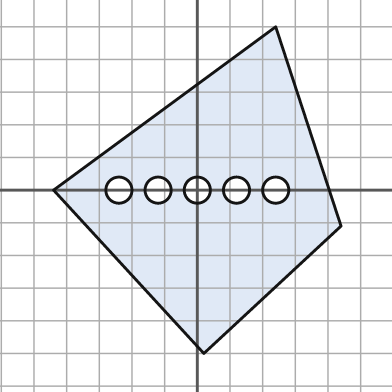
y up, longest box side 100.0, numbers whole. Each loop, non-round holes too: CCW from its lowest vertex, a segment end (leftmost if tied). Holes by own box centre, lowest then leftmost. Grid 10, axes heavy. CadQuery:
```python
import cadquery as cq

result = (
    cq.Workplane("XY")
    .moveTo(2.0, -50.0)
    .lineTo(44.0, -11.0)
    .lineTo(24.0, 50.0)
    .lineTo(-44.0, 0.0)
    .close()
    .moveTo(-24.0, 0.0)
    .circle(4.0)
    .moveTo(-12.0, 0.0)
    .circle(4.0)
    .moveTo(0.0, 0.0)
    .circle(4.0)
    .moveTo(12.0, 0.0)
    .circle(4.0)
    .moveTo(24.0, 0.0)
    .circle(4.0)
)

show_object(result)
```